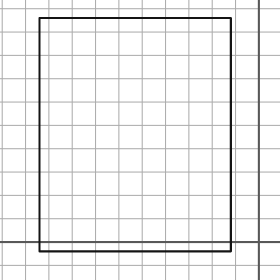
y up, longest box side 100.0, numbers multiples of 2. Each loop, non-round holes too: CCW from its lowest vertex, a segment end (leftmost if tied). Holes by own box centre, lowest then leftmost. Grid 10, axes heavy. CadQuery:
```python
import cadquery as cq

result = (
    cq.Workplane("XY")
    .moveTo(-94.0, -4.0)
    .lineTo(-12.0, -4.0)
    .lineTo(-12.0, 96.0)
    .lineTo(-94.0, 96.0)
    .close()
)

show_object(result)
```